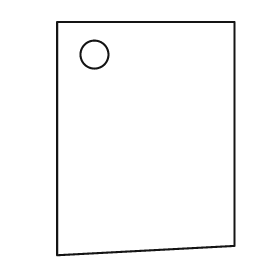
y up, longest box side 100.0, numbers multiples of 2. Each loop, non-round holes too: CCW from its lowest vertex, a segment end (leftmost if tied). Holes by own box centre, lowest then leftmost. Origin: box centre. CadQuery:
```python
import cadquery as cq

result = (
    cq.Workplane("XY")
    .moveTo(-38.0, -50.0)
    .lineTo(38.0, -46.0)
    .lineTo(38.0, 50.0)
    .lineTo(-38.0, 50.0)
    .close()
    .moveTo(-22.0, 36.0)
    .circle(6.0)
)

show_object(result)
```